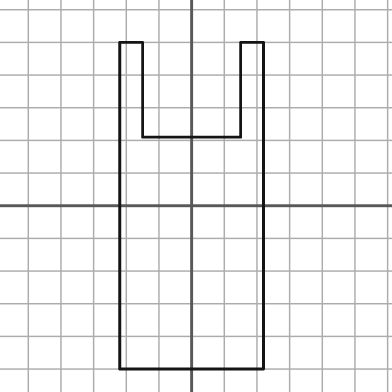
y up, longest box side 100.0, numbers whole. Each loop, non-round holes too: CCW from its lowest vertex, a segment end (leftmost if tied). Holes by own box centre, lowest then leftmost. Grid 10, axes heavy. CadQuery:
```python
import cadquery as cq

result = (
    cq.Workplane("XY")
    .moveTo(-22.0, -50.0)
    .lineTo(22.0, -50.0)
    .lineTo(22.0, 50.0)
    .lineTo(15.0, 50.0)
    .lineTo(15.0, 21.0)
    .lineTo(-15.0, 21.0)
    .lineTo(-15.0, 50.0)
    .lineTo(-22.0, 50.0)
    .close()
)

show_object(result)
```